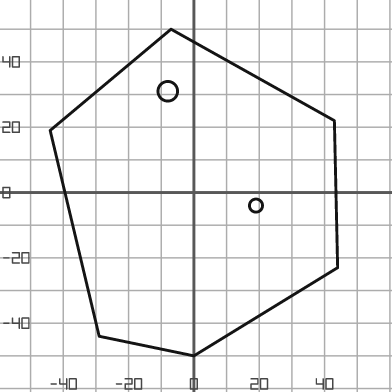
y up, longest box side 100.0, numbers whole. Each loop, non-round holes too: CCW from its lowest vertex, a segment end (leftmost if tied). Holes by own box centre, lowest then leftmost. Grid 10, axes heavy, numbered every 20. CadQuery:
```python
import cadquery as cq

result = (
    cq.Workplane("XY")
    .moveTo(0.0, -50.0)
    .lineTo(44.0, -23.0)
    .lineTo(43.0, 22.0)
    .lineTo(-7.0, 50.0)
    .lineTo(-44.0, 19.0)
    .lineTo(-29.0, -44.0)
    .close()
    .moveTo(19.0, -4.0)
    .circle(2.0)
    .moveTo(-8.0, 31.0)
    .circle(3.0)
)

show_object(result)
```